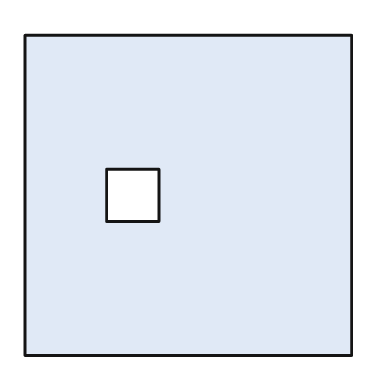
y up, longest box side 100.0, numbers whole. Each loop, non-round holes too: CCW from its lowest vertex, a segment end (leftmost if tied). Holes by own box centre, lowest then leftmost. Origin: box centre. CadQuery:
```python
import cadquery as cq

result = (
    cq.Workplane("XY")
    .moveTo(-50.0, -49.0)
    .lineTo(50.0, -49.0)
    .lineTo(50.0, 49.0)
    .lineTo(-50.0, 49.0)
    .close()
    .moveTo(-25.0, -8.0)
    .lineTo(-9.0, -8.0)
    .lineTo(-9.0, 8.0)
    .lineTo(-25.0, 8.0)
    .close()
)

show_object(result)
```